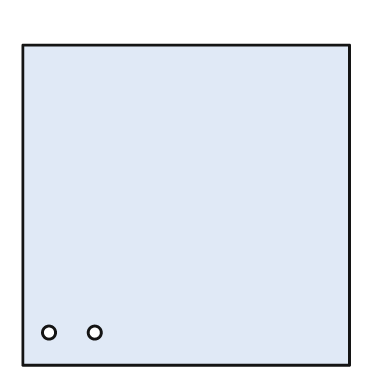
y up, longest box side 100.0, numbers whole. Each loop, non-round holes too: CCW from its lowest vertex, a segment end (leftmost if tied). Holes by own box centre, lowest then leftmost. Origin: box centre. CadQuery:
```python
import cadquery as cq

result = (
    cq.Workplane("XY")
    .moveTo(-50.0, -49.0)
    .lineTo(50.0, -49.0)
    .lineTo(50.0, 49.0)
    .lineTo(-50.0, 49.0)
    .close()
    .moveTo(-42.0, -39.0)
    .circle(2.0)
    .moveTo(-28.0, -39.0)
    .circle(2.0)
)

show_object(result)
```